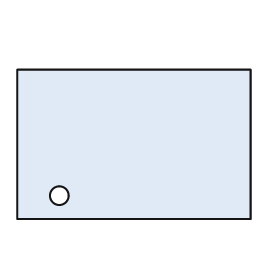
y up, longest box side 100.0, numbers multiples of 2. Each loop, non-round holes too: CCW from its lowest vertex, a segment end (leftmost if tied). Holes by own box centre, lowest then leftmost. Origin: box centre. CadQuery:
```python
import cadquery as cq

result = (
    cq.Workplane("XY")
    .moveTo(-50.0, -32.0)
    .lineTo(50.0, -32.0)
    .lineTo(50.0, 32.0)
    .lineTo(-50.0, 32.0)
    .close()
    .moveTo(-32.0, -22.0)
    .circle(4.0)
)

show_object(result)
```